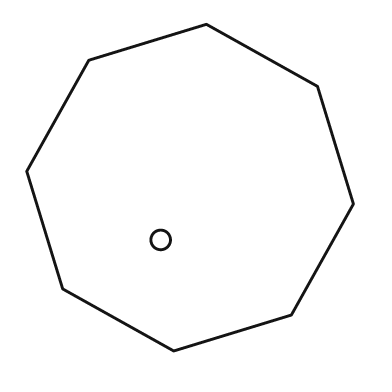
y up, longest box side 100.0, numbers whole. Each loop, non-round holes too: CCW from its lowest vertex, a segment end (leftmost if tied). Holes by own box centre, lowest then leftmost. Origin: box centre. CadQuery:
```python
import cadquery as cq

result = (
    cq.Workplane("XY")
    .moveTo(-5.0, -50.0)
    .lineTo(31.0, -39.0)
    .lineTo(50.0, -5.0)
    .lineTo(39.0, 31.0)
    .lineTo(5.0, 50.0)
    .lineTo(-31.0, 39.0)
    .lineTo(-50.0, 5.0)
    .lineTo(-39.0, -31.0)
    .close()
    .moveTo(-9.0, -16.0)
    .circle(3.0)
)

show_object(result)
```